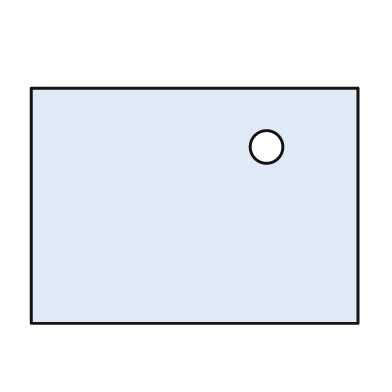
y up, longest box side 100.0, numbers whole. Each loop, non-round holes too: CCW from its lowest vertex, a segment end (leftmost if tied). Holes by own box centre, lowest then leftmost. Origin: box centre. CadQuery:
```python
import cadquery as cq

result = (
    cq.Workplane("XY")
    .moveTo(-50.0, -36.0)
    .lineTo(50.0, -36.0)
    .lineTo(50.0, 36.0)
    .lineTo(-50.0, 36.0)
    .close()
    .moveTo(22.0, 18.0)
    .circle(5.0)
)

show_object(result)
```